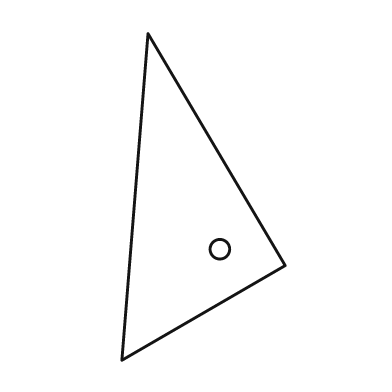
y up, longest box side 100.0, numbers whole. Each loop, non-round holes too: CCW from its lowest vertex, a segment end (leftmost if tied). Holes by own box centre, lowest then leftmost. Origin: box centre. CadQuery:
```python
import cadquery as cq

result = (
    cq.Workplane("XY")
    .moveTo(-25.0, -50.0)
    .lineTo(25.0, -21.0)
    .lineTo(-17.0, 50.0)
    .close()
    .moveTo(5.0, -16.0)
    .circle(3.0)
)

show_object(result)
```